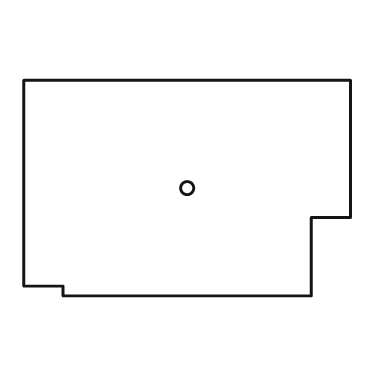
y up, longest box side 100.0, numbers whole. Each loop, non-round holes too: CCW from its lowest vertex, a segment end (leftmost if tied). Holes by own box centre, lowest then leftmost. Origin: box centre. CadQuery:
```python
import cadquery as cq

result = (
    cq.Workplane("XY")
    .moveTo(-38.0, -33.0)
    .lineTo(38.0, -33.0)
    .lineTo(38.0, -9.0)
    .lineTo(50.0, -9.0)
    .lineTo(50.0, 33.0)
    .lineTo(-50.0, 33.0)
    .lineTo(-50.0, -30.0)
    .lineTo(-38.0, -30.0)
    .close()
    .moveTo(0.0, 0.0)
    .circle(2.0)
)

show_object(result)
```